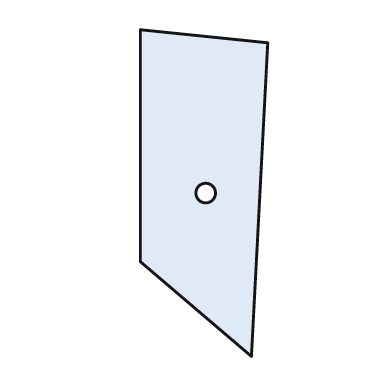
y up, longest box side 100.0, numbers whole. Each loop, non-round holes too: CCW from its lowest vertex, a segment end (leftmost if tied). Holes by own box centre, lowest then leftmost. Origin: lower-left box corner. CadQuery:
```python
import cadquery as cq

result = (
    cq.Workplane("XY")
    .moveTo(34.0, 0.0)
    .lineTo(39.0, 96.0)
    .lineTo(0.0, 100.0)
    .lineTo(0.0, 29.0)
    .close()
    .moveTo(20.0, 50.0)
    .circle(3.0)
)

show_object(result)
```